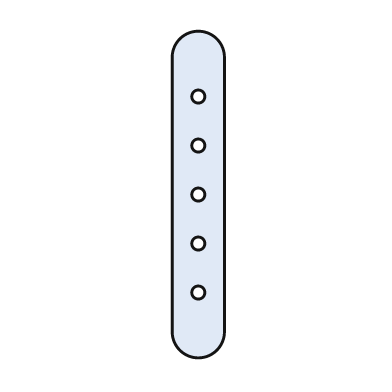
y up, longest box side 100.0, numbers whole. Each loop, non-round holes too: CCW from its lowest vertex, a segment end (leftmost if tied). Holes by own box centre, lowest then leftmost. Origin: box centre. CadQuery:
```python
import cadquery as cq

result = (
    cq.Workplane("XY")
    .moveTo(-8.0, -42.0)
    .threePointArc((0.0, -50.0), (8.0, -42.0))
    .lineTo(8.0, 42.0)
    .threePointArc((0.0, 50.0), (-8.0, 42.0))
    .close()
    .moveTo(0.0, -30.0)
    .circle(2.0)
    .moveTo(0.0, -15.0)
    .circle(2.0)
    .moveTo(0.0, 0.0)
    .circle(2.0)
    .moveTo(0.0, 15.0)
    .circle(2.0)
    .moveTo(0.0, 30.0)
    .circle(2.0)
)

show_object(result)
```